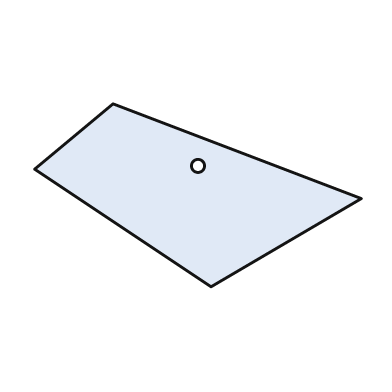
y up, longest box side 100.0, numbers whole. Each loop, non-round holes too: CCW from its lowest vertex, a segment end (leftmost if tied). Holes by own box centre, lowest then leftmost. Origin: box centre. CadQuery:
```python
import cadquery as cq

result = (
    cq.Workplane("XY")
    .moveTo(4.0, -28.0)
    .lineTo(50.0, -1.0)
    .lineTo(-26.0, 28.0)
    .lineTo(-50.0, 8.0)
    .close()
    .moveTo(0.0, 9.0)
    .circle(2.0)
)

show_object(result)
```